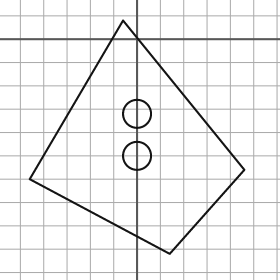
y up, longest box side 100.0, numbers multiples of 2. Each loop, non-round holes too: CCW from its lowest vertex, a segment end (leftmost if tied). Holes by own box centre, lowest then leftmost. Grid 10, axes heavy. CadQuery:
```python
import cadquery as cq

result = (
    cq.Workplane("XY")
    .moveTo(14.0, -92.0)
    .lineTo(46.0, -56.0)
    .lineTo(-6.0, 8.0)
    .lineTo(-46.0, -60.0)
    .close()
    .moveTo(0.0, -50.0)
    .circle(6.0)
    .moveTo(0.0, -32.0)
    .circle(6.0)
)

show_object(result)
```